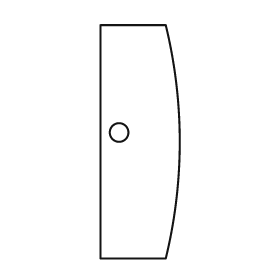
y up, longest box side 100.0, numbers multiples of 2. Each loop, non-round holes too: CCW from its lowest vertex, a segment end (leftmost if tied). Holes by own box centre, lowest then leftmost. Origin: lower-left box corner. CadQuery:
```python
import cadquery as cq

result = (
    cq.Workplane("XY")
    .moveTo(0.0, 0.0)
    .lineTo(28.0, 0.0)
    .threePointArc((34.0, 50.0), (28.0, 100.0))
    .lineTo(0.0, 100.0)
    .close()
    .moveTo(8.0, 54.0)
    .circle(4.0)
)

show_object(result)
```